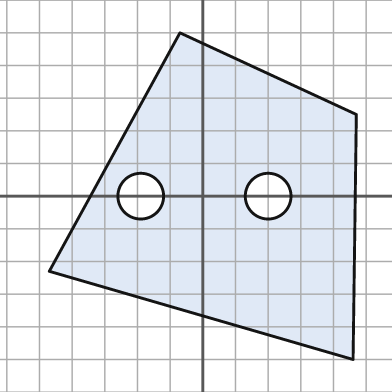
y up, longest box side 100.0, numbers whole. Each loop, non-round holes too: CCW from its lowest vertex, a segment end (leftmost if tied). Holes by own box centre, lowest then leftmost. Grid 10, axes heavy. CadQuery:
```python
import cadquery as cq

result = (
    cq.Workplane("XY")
    .moveTo(46.0, -50.0)
    .lineTo(47.0, 25.0)
    .lineTo(-7.0, 50.0)
    .lineTo(-47.0, -23.0)
    .close()
    .moveTo(-19.0, 0.0)
    .circle(7.0)
    .moveTo(20.0, 0.0)
    .circle(7.0)
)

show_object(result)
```